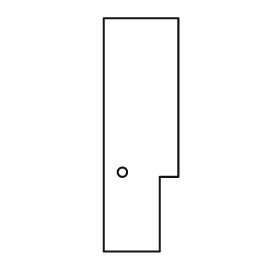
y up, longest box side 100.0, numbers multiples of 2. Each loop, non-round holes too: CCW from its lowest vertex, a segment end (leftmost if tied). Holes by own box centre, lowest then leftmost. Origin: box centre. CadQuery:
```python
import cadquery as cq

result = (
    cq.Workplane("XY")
    .moveTo(-16.0, -50.0)
    .lineTo(8.0, -50.0)
    .lineTo(8.0, -18.0)
    .lineTo(16.0, -18.0)
    .lineTo(16.0, 50.0)
    .lineTo(-16.0, 50.0)
    .close()
    .moveTo(-8.0, -16.0)
    .circle(2.0)
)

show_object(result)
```